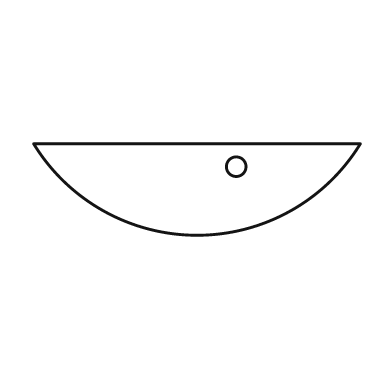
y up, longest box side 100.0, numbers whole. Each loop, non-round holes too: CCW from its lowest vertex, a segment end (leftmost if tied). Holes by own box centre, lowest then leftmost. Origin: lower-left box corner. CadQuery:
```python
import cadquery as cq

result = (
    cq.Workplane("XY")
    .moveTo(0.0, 28.0)
    .threePointArc((50.0, 0.0), (100.0, 28.0))
    .close()
    .moveTo(62.0, 21.0)
    .circle(3.0)
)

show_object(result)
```